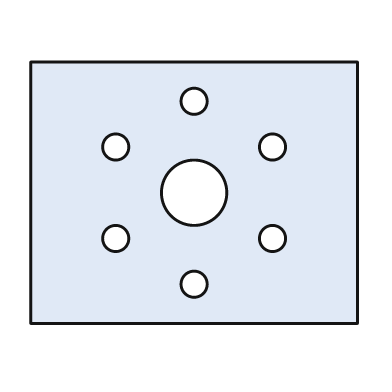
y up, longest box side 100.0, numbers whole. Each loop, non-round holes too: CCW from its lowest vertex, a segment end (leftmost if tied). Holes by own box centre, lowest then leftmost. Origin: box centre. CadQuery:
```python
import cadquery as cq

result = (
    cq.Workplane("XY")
    .moveTo(-50.0, -40.0)
    .lineTo(50.0, -40.0)
    .lineTo(50.0, 40.0)
    .lineTo(-50.0, 40.0)
    .close()
    .moveTo(0.0, -28.0)
    .circle(4.0)
    .moveTo(-24.0, -14.0)
    .circle(4.0)
    .moveTo(24.0, -14.0)
    .circle(4.0)
    .moveTo(0.0, 0.0)
    .circle(10.0)
    .moveTo(-24.0, 14.0)
    .circle(4.0)
    .moveTo(24.0, 14.0)
    .circle(4.0)
    .moveTo(0.0, 28.0)
    .circle(4.0)
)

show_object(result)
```